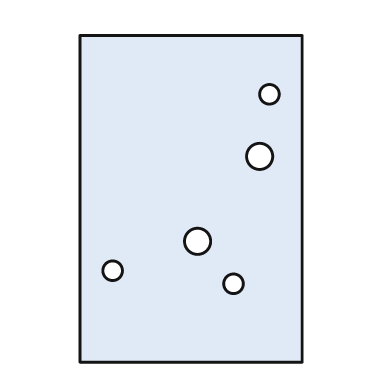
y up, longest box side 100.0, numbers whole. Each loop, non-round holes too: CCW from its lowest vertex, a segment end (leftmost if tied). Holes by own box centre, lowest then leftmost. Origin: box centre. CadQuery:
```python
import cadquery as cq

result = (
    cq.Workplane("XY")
    .moveTo(-34.0, -50.0)
    .lineTo(34.0, -50.0)
    .lineTo(34.0, 50.0)
    .lineTo(-34.0, 50.0)
    .close()
    .moveTo(13.0, -26.0)
    .circle(3.0)
    .moveTo(-24.0, -22.0)
    .circle(3.0)
    .moveTo(2.0, -13.0)
    .circle(4.0)
    .moveTo(21.0, 13.0)
    .circle(4.0)
    .moveTo(24.0, 32.0)
    .circle(3.0)
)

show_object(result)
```